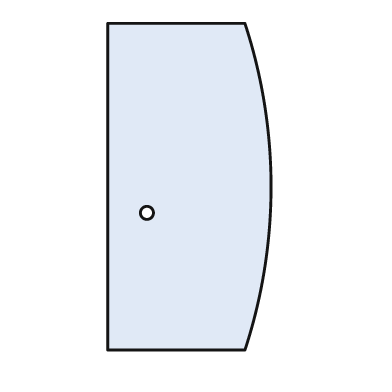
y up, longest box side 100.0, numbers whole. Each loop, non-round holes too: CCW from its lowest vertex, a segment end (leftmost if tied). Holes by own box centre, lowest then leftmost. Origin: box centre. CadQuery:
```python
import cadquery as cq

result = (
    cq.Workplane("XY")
    .moveTo(-25.0, -50.0)
    .lineTo(17.0, -50.0)
    .threePointArc((25.0, 0.0), (17.0, 50.0))
    .lineTo(-25.0, 50.0)
    .close()
    .moveTo(-13.0, -8.0)
    .circle(2.0)
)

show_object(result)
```